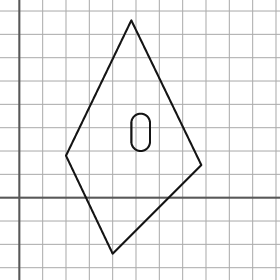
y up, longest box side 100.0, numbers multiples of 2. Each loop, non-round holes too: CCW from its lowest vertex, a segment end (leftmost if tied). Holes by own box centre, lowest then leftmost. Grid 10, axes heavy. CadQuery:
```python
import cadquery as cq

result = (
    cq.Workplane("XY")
    .moveTo(40.0, -24.0)
    .lineTo(78.0, 14.0)
    .lineTo(48.0, 76.0)
    .lineTo(20.0, 18.0)
    .close()
    .moveTo(48.0, 24.0)
    .threePointArc((52.0, 20.0), (56.0, 24.0))
    .lineTo(56.0, 32.0)
    .threePointArc((52.0, 36.0), (48.0, 32.0))
    .close()
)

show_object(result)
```